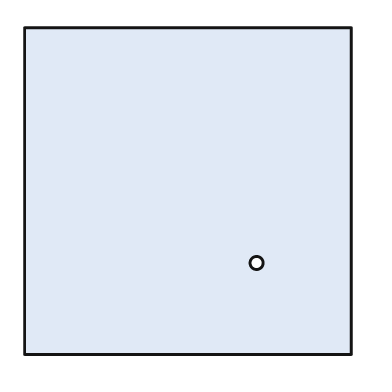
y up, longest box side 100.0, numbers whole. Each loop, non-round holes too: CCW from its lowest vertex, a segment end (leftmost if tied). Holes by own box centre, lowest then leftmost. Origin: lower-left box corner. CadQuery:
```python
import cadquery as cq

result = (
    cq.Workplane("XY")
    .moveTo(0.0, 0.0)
    .lineTo(100.0, 0.0)
    .lineTo(100.0, 100.0)
    .lineTo(0.0, 100.0)
    .close()
    .moveTo(71.0, 28.0)
    .circle(2.0)
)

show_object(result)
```